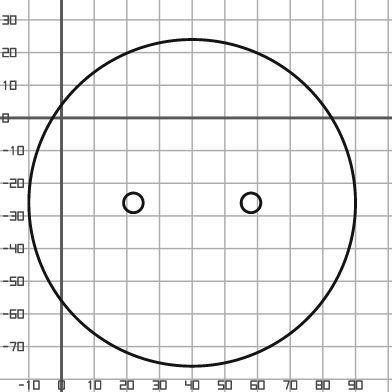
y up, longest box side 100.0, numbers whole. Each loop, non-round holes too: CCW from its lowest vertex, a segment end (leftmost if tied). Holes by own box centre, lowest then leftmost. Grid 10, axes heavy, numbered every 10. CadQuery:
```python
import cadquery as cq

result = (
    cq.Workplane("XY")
    .moveTo(40.0, -26.0)
    .circle(50.0)
    .moveTo(22.0, -26.0)
    .circle(3.0)
    .moveTo(58.0, -26.0)
    .circle(3.0)
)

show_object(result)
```